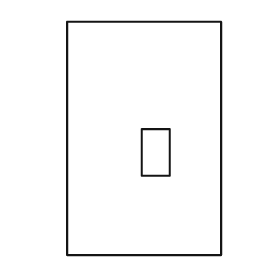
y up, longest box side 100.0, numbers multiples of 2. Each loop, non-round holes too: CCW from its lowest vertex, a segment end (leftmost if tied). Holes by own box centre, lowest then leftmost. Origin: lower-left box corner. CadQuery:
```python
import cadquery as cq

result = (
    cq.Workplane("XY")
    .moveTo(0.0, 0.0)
    .lineTo(66.0, 0.0)
    .lineTo(66.0, 100.0)
    .lineTo(0.0, 100.0)
    .close()
    .moveTo(32.0, 34.0)
    .lineTo(44.0, 34.0)
    .lineTo(44.0, 54.0)
    .lineTo(32.0, 54.0)
    .close()
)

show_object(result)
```